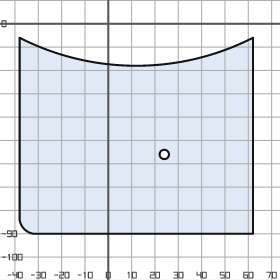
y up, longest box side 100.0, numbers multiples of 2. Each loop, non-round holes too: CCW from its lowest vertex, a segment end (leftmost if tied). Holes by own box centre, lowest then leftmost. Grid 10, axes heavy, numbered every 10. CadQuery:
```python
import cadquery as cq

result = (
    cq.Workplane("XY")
    .moveTo(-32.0, -90.0)
    .lineTo(62.0, -90.0)
    .lineTo(62.0, -6.0)
    .threePointArc((12.0, -18.0), (-38.0, -6.0))
    .lineTo(-38.0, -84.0)
    .threePointArc((-36.0, -88.0), (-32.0, -90.0))
    .close()
    .moveTo(24.0, -56.0)
    .circle(2.0)
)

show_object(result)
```